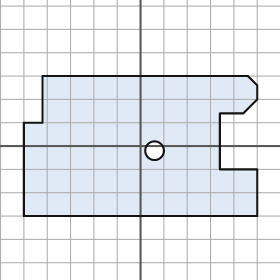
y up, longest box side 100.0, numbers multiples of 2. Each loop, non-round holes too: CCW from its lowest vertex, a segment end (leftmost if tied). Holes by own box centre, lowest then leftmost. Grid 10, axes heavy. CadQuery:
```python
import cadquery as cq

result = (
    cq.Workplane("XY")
    .moveTo(-50.0, -30.0)
    .lineTo(50.0, -30.0)
    .lineTo(50.0, -10.0)
    .lineTo(34.0, -10.0)
    .lineTo(34.0, 14.0)
    .lineTo(44.0, 14.0)
    .lineTo(50.0, 20.0)
    .lineTo(50.0, 26.0)
    .lineTo(46.0, 30.0)
    .lineTo(-42.0, 30.0)
    .lineTo(-42.0, 10.0)
    .lineTo(-50.0, 10.0)
    .close()
    .moveTo(6.0, -2.0)
    .circle(4.0)
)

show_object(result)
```